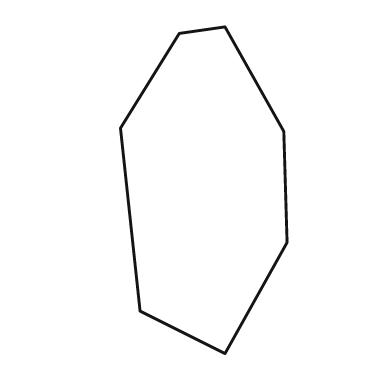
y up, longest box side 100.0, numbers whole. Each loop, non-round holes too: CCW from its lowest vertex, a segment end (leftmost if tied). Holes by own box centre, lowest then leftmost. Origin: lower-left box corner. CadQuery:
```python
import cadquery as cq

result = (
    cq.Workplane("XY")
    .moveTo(32.0, 0.0)
    .lineTo(51.0, 34.0)
    .lineTo(50.0, 68.0)
    .lineTo(32.0, 100.0)
    .lineTo(18.0, 98.0)
    .lineTo(0.0, 69.0)
    .lineTo(6.0, 13.0)
    .close()
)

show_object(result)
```